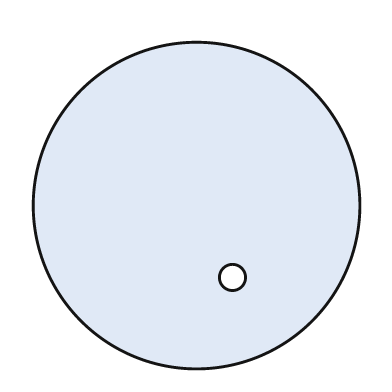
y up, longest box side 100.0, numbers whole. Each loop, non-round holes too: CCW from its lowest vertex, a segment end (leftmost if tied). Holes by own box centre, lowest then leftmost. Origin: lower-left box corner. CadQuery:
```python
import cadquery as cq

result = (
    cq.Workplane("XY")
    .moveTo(50.0, 50.0)
    .circle(50.0)
    .moveTo(61.0, 28.0)
    .circle(4.0)
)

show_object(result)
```